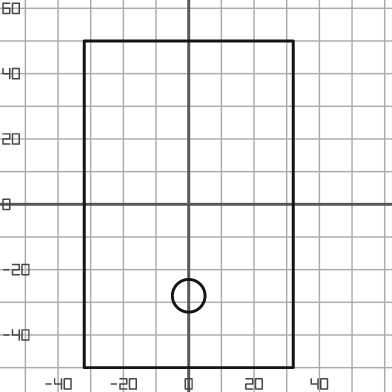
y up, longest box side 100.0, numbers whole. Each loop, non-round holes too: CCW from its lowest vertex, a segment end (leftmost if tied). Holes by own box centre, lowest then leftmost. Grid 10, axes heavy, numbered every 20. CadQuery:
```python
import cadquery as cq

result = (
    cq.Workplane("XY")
    .moveTo(-32.0, -50.0)
    .lineTo(32.0, -50.0)
    .lineTo(32.0, 50.0)
    .lineTo(-32.0, 50.0)
    .close()
    .moveTo(0.0, -28.0)
    .circle(5.0)
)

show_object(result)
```